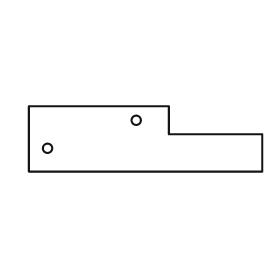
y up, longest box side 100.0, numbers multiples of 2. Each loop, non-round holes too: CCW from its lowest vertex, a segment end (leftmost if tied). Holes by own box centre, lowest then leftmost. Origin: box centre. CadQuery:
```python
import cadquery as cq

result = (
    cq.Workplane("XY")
    .moveTo(-50.0, -14.0)
    .lineTo(50.0, -14.0)
    .lineTo(50.0, 2.0)
    .lineTo(10.0, 2.0)
    .lineTo(10.0, 14.0)
    .lineTo(-50.0, 14.0)
    .close()
    .moveTo(-42.0, -4.0)
    .circle(2.0)
    .moveTo(-4.0, 8.0)
    .circle(2.0)
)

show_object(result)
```